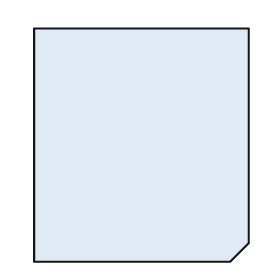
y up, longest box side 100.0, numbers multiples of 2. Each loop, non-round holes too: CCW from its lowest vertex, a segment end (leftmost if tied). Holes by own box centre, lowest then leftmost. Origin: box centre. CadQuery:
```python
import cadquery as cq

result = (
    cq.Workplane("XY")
    .moveTo(-46.0, -50.0)
    .lineTo(38.0, -50.0)
    .lineTo(46.0, -42.0)
    .lineTo(46.0, 50.0)
    .lineTo(-46.0, 50.0)
    .close()
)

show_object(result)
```